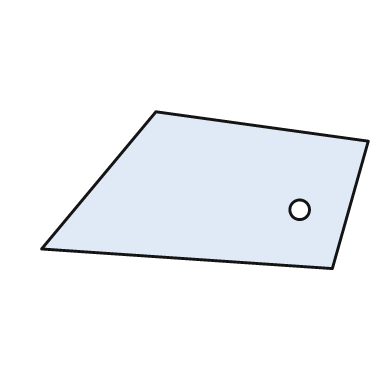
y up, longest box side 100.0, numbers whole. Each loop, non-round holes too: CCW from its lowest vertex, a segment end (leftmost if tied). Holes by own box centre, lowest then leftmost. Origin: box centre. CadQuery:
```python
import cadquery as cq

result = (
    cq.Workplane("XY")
    .moveTo(39.0, -24.0)
    .lineTo(50.0, 15.0)
    .lineTo(-15.0, 24.0)
    .lineTo(-50.0, -18.0)
    .close()
    .moveTo(29.0, -6.0)
    .circle(3.0)
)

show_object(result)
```